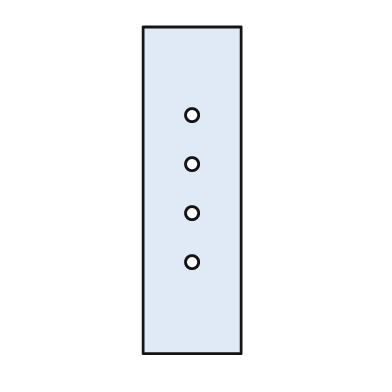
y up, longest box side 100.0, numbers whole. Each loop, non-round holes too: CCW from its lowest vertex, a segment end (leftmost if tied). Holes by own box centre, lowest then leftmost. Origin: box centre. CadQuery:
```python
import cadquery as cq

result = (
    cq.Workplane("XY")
    .moveTo(-15.0, -50.0)
    .lineTo(15.0, -50.0)
    .lineTo(15.0, 50.0)
    .lineTo(-15.0, 50.0)
    .close()
    .moveTo(0.0, -22.0)
    .circle(2.0)
    .moveTo(0.0, -7.0)
    .circle(2.0)
    .moveTo(0.0, 8.0)
    .circle(2.0)
    .moveTo(0.0, 23.0)
    .circle(2.0)
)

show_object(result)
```